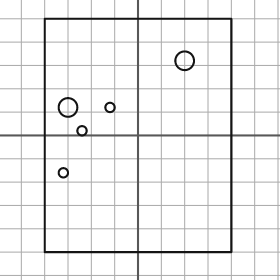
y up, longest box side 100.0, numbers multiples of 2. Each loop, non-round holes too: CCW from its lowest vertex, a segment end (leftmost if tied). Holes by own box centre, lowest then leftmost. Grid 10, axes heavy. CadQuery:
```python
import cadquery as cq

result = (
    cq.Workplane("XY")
    .moveTo(-40.0, -50.0)
    .lineTo(40.0, -50.0)
    .lineTo(40.0, 50.0)
    .lineTo(-40.0, 50.0)
    .close()
    .moveTo(-32.0, -16.0)
    .circle(2.0)
    .moveTo(-24.0, 2.0)
    .circle(2.0)
    .moveTo(-30.0, 12.0)
    .circle(4.0)
    .moveTo(-12.0, 12.0)
    .circle(2.0)
    .moveTo(20.0, 32.0)
    .circle(4.0)
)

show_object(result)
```